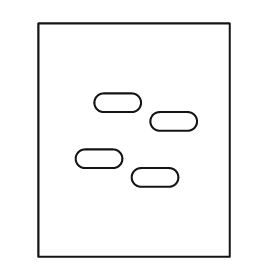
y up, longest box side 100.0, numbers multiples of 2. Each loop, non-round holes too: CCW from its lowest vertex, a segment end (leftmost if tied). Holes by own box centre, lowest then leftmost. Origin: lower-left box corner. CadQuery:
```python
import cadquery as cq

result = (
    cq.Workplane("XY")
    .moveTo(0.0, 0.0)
    .lineTo(82.0, 0.0)
    .lineTo(82.0, 100.0)
    .lineTo(0.0, 100.0)
    .close()
    .moveTo(44.0, 30.0)
    .lineTo(56.0, 30.0)
    .threePointArc((60.0, 34.0), (56.0, 38.0))
    .lineTo(44.0, 38.0)
    .threePointArc((40.0, 34.0), (44.0, 30.0))
    .close()
    .moveTo(20.0, 38.0)
    .lineTo(32.0, 38.0)
    .threePointArc((36.0, 42.0), (32.0, 46.0))
    .lineTo(20.0, 46.0)
    .threePointArc((16.0, 42.0), (20.0, 38.0))
    .close()
    .moveTo(52.0, 54.0)
    .lineTo(64.0, 54.0)
    .threePointArc((68.0, 58.0), (64.0, 62.0))
    .lineTo(52.0, 62.0)
    .threePointArc((48.0, 58.0), (52.0, 54.0))
    .close()
    .moveTo(28.0, 62.0)
    .lineTo(40.0, 62.0)
    .threePointArc((44.0, 66.0), (40.0, 70.0))
    .lineTo(28.0, 70.0)
    .threePointArc((24.0, 66.0), (28.0, 62.0))
    .close()
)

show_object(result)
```